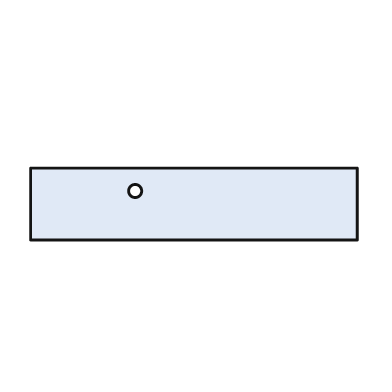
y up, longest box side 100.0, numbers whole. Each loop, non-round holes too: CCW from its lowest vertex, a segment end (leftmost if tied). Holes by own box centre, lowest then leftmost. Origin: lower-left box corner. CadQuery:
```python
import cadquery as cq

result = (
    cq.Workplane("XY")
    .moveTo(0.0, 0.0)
    .lineTo(100.0, 0.0)
    .lineTo(100.0, 22.0)
    .lineTo(0.0, 22.0)
    .close()
    .moveTo(32.0, 15.0)
    .circle(2.0)
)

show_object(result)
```